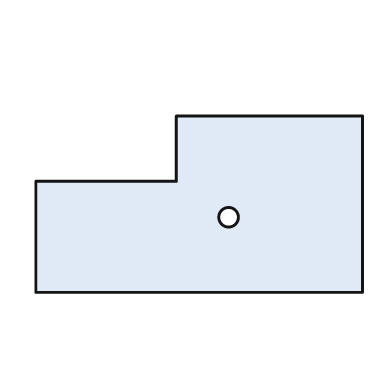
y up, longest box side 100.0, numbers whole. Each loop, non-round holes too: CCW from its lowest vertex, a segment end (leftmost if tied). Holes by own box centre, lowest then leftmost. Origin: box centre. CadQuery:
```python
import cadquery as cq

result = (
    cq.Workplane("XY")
    .moveTo(-50.0, -27.0)
    .lineTo(50.0, -27.0)
    .lineTo(50.0, 27.0)
    .lineTo(-7.0, 27.0)
    .lineTo(-7.0, 7.0)
    .lineTo(-50.0, 7.0)
    .close()
    .moveTo(9.0, -4.0)
    .circle(3.0)
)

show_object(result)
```